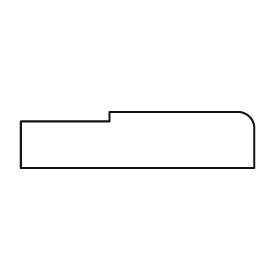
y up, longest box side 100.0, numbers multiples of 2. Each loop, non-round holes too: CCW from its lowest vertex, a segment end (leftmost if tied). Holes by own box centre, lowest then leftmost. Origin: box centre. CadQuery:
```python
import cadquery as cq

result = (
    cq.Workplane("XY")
    .moveTo(-50.0, -12.0)
    .lineTo(50.0, -12.0)
    .lineTo(50.0, 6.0)
    .threePointArc((48.0, 10.0), (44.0, 12.0))
    .lineTo(-12.0, 12.0)
    .lineTo(-12.0, 8.0)
    .lineTo(-50.0, 8.0)
    .close()
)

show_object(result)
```